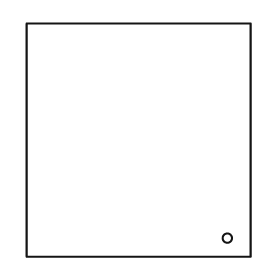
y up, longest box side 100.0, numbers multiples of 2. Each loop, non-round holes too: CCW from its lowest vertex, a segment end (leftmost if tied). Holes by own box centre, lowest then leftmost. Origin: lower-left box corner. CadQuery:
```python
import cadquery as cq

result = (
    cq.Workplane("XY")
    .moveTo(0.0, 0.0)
    .lineTo(96.0, 0.0)
    .lineTo(96.0, 100.0)
    .lineTo(0.0, 100.0)
    .close()
    .moveTo(86.0, 8.0)
    .circle(2.0)
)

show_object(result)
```